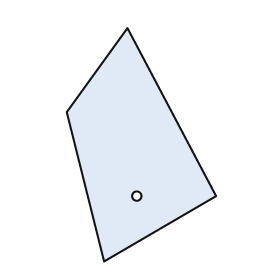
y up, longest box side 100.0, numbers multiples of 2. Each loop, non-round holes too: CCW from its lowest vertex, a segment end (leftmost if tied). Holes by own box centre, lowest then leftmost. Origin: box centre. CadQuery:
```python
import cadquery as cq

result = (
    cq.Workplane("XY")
    .moveTo(-16.0, -50.0)
    .lineTo(32.0, -22.0)
    .lineTo(-6.0, 50.0)
    .lineTo(-32.0, 14.0)
    .close()
    .moveTo(-2.0, -22.0)
    .circle(2.0)
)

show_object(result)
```